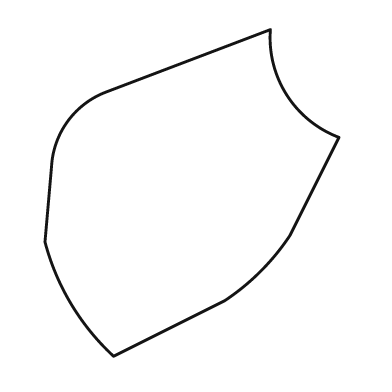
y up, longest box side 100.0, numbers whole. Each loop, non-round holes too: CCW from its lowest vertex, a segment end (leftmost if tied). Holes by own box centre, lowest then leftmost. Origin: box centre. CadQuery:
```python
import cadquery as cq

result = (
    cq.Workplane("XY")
    .moveTo(-24.0, -50.0)
    .lineTo(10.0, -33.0)
    .threePointArc((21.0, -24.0), (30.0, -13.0))
    .lineTo(45.0, 17.0)
    .threePointArc((29.0, 30.0), (24.0, 50.0))
    .lineTo(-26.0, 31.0)
    .threePointArc((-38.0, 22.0), (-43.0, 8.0))
    .lineTo(-45.0, -15.0)
    .threePointArc((-37.0, -34.0), (-24.0, -50.0))
    .close()
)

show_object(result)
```